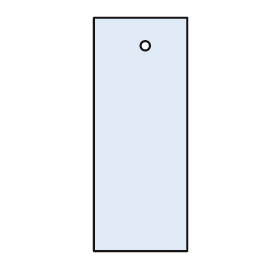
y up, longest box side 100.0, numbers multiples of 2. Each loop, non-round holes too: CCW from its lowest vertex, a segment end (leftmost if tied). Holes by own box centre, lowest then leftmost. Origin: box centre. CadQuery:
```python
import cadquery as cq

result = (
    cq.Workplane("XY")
    .moveTo(-20.0, -50.0)
    .lineTo(20.0, -50.0)
    .lineTo(20.0, 50.0)
    .lineTo(-20.0, 50.0)
    .close()
    .moveTo(2.0, 38.0)
    .circle(2.0)
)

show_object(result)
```